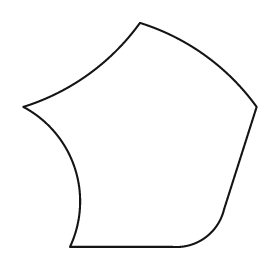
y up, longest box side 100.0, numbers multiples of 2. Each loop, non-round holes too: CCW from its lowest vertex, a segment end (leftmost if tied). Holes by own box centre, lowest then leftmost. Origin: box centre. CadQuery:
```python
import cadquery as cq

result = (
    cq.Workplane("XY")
    .moveTo(-30.0, -48.0)
    .lineTo(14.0, -48.0)
    .threePointArc((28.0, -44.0), (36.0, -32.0))
    .lineTo(50.0, 12.0)
    .threePointArc((28.0, 34.0), (0.0, 48.0))
    .threePointArc((-22.0, 26.0), (-50.0, 12.0))
    .threePointArc((-28.0, -14.0), (-30.0, -48.0))
    .close()
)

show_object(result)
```